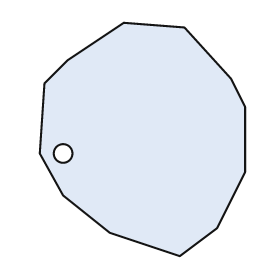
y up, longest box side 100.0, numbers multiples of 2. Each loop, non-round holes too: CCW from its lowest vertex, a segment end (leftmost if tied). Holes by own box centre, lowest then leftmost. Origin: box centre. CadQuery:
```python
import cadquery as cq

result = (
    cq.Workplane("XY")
    .moveTo(16.0, -50.0)
    .lineTo(32.0, -38.0)
    .lineTo(44.0, -14.0)
    .lineTo(44.0, 14.0)
    .lineTo(38.0, 26.0)
    .lineTo(18.0, 48.0)
    .lineTo(-8.0, 50.0)
    .lineTo(-32.0, 34.0)
    .lineTo(-42.0, 24.0)
    .lineTo(-44.0, -6.0)
    .lineTo(-34.0, -24.0)
    .lineTo(-14.0, -40.0)
    .close()
    .moveTo(-34.0, -6.0)
    .circle(4.0)
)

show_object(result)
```